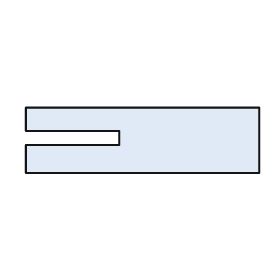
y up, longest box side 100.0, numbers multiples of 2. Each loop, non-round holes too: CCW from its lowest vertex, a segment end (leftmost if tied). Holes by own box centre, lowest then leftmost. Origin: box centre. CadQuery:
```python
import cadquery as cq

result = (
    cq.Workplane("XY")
    .moveTo(-50.0, -14.0)
    .lineTo(50.0, -14.0)
    .lineTo(50.0, 14.0)
    .lineTo(-50.0, 14.0)
    .lineTo(-50.0, 4.0)
    .lineTo(-10.0, 4.0)
    .lineTo(-10.0, -2.0)
    .lineTo(-50.0, -2.0)
    .close()
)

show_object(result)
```